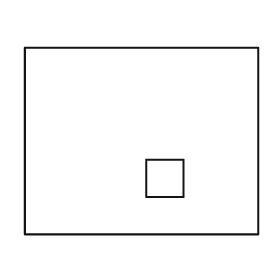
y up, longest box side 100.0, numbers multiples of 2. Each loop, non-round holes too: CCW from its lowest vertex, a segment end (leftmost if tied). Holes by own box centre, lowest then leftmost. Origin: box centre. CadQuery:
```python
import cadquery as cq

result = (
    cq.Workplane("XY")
    .moveTo(-50.0, -40.0)
    .lineTo(50.0, -40.0)
    .lineTo(50.0, 40.0)
    .lineTo(-50.0, 40.0)
    .close()
    .moveTo(2.0, -24.0)
    .lineTo(18.0, -24.0)
    .lineTo(18.0, -8.0)
    .lineTo(2.0, -8.0)
    .close()
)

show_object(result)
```